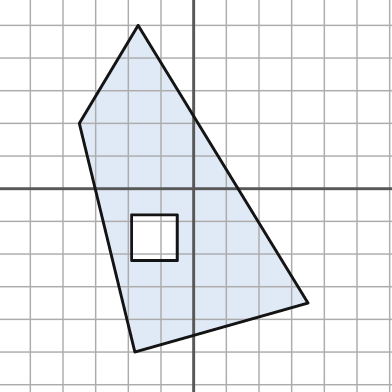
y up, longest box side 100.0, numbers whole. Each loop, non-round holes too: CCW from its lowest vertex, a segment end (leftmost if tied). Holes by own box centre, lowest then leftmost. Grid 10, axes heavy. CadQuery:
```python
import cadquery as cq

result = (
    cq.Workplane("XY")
    .moveTo(-18.0, -50.0)
    .lineTo(35.0, -35.0)
    .lineTo(-17.0, 50.0)
    .lineTo(-35.0, 20.0)
    .close()
    .moveTo(-19.0, -22.0)
    .lineTo(-5.0, -22.0)
    .lineTo(-5.0, -8.0)
    .lineTo(-19.0, -8.0)
    .close()
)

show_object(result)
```